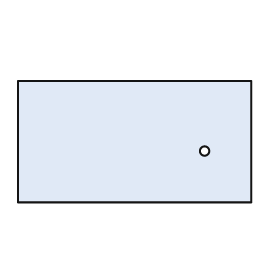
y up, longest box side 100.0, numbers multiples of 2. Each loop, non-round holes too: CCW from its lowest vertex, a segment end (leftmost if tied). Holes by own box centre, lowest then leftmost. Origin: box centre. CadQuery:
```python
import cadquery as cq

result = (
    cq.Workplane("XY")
    .moveTo(-50.0, -26.0)
    .lineTo(50.0, -26.0)
    .lineTo(50.0, 26.0)
    .lineTo(-50.0, 26.0)
    .close()
    .moveTo(30.0, -4.0)
    .circle(2.0)
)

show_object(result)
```